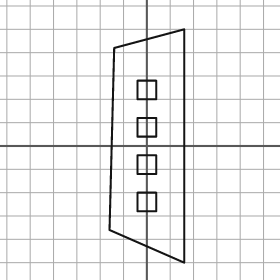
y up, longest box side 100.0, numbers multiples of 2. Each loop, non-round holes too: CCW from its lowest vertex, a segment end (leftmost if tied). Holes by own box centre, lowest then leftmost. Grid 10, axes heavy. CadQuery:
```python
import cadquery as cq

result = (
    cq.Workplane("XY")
    .moveTo(16.0, -50.0)
    .lineTo(16.0, 50.0)
    .lineTo(-14.0, 42.0)
    .lineTo(-16.0, -36.0)
    .close()
    .moveTo(-4.0, -28.0)
    .lineTo(4.0, -28.0)
    .lineTo(4.0, -20.0)
    .lineTo(-4.0, -20.0)
    .close()
    .moveTo(-4.0, -12.0)
    .lineTo(4.0, -12.0)
    .lineTo(4.0, -4.0)
    .lineTo(-4.0, -4.0)
    .close()
    .moveTo(-4.0, 4.0)
    .lineTo(4.0, 4.0)
    .lineTo(4.0, 12.0)
    .lineTo(-4.0, 12.0)
    .close()
    .moveTo(-4.0, 20.0)
    .lineTo(4.0, 20.0)
    .lineTo(4.0, 28.0)
    .lineTo(-4.0, 28.0)
    .close()
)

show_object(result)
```